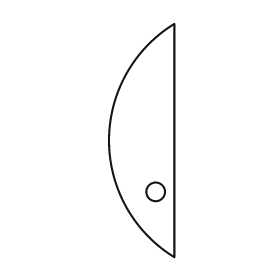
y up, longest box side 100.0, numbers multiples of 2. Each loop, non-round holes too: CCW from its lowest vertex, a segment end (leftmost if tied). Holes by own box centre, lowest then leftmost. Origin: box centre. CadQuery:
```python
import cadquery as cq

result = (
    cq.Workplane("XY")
    .moveTo(14.0, -50.0)
    .lineTo(14.0, 50.0)
    .threePointArc((-14.0, 0.0), (14.0, -50.0))
    .close()
    .moveTo(6.0, -22.0)
    .circle(4.0)
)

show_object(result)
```